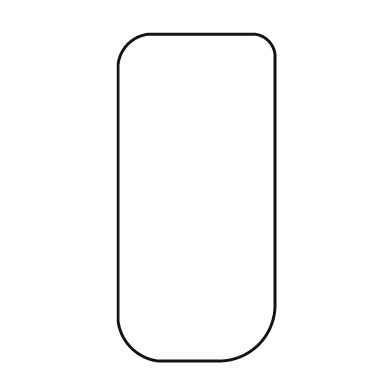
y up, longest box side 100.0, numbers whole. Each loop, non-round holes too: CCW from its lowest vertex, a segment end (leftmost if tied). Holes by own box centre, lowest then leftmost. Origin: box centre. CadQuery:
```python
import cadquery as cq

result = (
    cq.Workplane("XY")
    .moveTo(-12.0, -50.0)
    .lineTo(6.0, -50.0)
    .threePointArc((19.0, -45.0), (24.0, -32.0))
    .lineTo(24.0, 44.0)
    .threePointArc((22.0, 48.0), (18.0, 50.0))
    .lineTo(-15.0, 50.0)
    .threePointArc((-21.0, 47.0), (-24.0, 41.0))
    .lineTo(-24.0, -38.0)
    .threePointArc((-20.0, -46.0), (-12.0, -50.0))
    .close()
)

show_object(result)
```